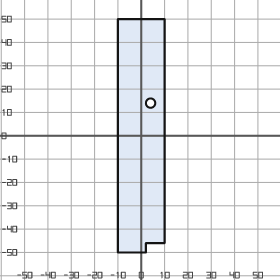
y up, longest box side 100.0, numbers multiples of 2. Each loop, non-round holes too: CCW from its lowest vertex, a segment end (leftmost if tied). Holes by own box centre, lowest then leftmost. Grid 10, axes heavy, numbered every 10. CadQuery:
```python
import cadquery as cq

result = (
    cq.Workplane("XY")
    .moveTo(-10.0, -50.0)
    .lineTo(2.0, -50.0)
    .lineTo(2.0, -46.0)
    .lineTo(10.0, -46.0)
    .lineTo(10.0, 50.0)
    .lineTo(-10.0, 50.0)
    .close()
    .moveTo(4.0, 14.0)
    .circle(2.0)
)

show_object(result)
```